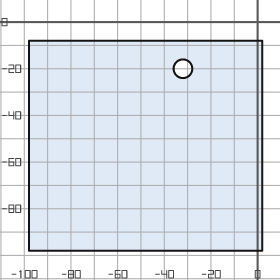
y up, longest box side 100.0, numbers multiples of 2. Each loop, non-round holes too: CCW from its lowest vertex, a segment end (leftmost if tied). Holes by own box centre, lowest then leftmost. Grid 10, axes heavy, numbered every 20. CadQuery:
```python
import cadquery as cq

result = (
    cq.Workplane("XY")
    .moveTo(-98.0, -98.0)
    .lineTo(2.0, -98.0)
    .lineTo(2.0, -8.0)
    .lineTo(-98.0, -8.0)
    .close()
    .moveTo(-32.0, -20.0)
    .circle(4.0)
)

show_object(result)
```